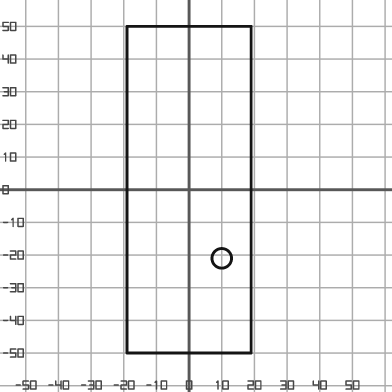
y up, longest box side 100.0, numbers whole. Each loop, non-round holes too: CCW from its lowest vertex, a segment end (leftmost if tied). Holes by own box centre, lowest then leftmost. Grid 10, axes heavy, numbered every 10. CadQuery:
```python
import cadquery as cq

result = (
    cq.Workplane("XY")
    .moveTo(-19.0, -50.0)
    .lineTo(19.0, -50.0)
    .lineTo(19.0, 50.0)
    .lineTo(-19.0, 50.0)
    .close()
    .moveTo(10.0, -21.0)
    .circle(3.0)
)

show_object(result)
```